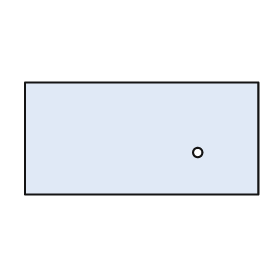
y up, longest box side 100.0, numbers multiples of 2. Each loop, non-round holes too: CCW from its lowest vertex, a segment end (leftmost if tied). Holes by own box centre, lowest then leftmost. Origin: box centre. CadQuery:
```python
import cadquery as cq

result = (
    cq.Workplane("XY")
    .moveTo(-50.0, -24.0)
    .lineTo(50.0, -24.0)
    .lineTo(50.0, 24.0)
    .lineTo(-50.0, 24.0)
    .close()
    .moveTo(24.0, -6.0)
    .circle(2.0)
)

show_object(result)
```